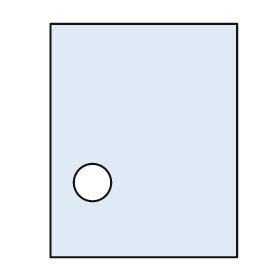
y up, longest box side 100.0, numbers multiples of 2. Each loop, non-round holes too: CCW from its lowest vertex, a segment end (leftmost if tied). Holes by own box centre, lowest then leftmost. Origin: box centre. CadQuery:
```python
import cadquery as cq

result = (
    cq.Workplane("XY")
    .moveTo(-40.0, -50.0)
    .lineTo(40.0, -50.0)
    .lineTo(40.0, 50.0)
    .lineTo(-40.0, 50.0)
    .close()
    .moveTo(-22.0, -18.0)
    .circle(8.0)
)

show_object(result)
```